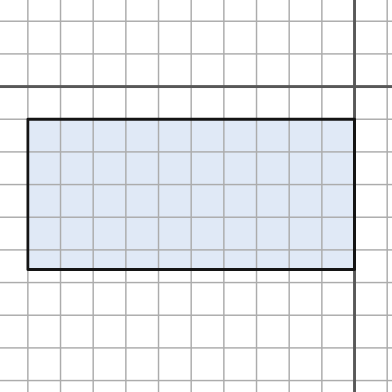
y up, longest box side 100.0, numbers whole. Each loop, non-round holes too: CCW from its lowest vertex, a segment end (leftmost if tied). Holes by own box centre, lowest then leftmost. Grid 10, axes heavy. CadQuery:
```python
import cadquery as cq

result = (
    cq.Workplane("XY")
    .moveTo(-100.0, -56.0)
    .lineTo(0.0, -56.0)
    .lineTo(0.0, -10.0)
    .lineTo(-100.0, -10.0)
    .close()
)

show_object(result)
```